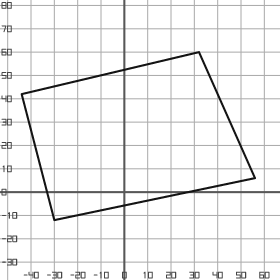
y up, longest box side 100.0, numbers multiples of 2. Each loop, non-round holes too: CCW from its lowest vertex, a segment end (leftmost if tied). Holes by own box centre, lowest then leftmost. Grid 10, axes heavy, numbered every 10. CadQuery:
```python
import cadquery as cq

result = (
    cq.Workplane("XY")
    .moveTo(-30.0, -12.0)
    .lineTo(56.0, 6.0)
    .lineTo(32.0, 60.0)
    .lineTo(-44.0, 42.0)
    .close()
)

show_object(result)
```